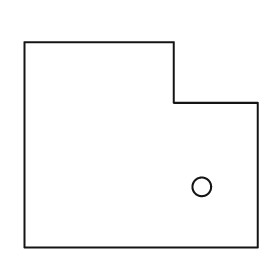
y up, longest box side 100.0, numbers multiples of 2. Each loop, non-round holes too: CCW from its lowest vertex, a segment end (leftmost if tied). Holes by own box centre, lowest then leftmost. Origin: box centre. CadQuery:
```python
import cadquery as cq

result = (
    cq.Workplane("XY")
    .moveTo(-50.0, -44.0)
    .lineTo(50.0, -44.0)
    .lineTo(50.0, 18.0)
    .lineTo(14.0, 18.0)
    .lineTo(14.0, 44.0)
    .lineTo(-50.0, 44.0)
    .close()
    .moveTo(26.0, -18.0)
    .circle(4.0)
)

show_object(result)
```